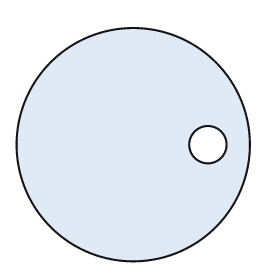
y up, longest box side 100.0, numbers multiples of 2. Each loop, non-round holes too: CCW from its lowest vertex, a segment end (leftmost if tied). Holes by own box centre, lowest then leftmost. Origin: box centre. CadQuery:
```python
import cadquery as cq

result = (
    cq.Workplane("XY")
    .moveTo(0.0, 0.0)
    .circle(50.0)
    .moveTo(32.0, 0.0)
    .circle(8.0)
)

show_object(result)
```